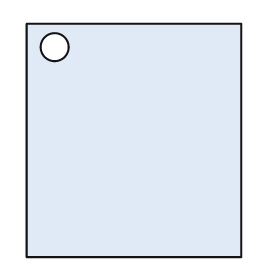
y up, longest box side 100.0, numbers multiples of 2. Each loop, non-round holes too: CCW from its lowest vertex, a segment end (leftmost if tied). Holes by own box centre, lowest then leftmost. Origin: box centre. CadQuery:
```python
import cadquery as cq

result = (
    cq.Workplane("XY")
    .moveTo(-46.0, -50.0)
    .lineTo(46.0, -50.0)
    .lineTo(46.0, 50.0)
    .lineTo(-46.0, 50.0)
    .close()
    .moveTo(-34.0, 40.0)
    .circle(6.0)
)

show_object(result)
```